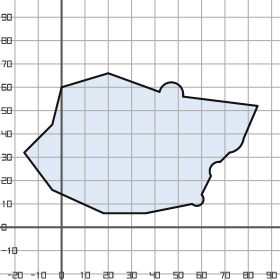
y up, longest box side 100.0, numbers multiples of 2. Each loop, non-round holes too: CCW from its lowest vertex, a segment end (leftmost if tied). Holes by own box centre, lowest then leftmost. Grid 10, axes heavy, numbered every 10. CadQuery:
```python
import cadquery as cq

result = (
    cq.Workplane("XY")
    .moveTo(18.0, 6.0)
    .lineTo(36.0, 6.0)
    .lineTo(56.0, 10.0)
    .threePointArc((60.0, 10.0), (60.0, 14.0))
    .lineTo(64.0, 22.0)
    .threePointArc((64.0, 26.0), (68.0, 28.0))
    .lineTo(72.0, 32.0)
    .threePointArc((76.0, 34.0), (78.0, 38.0))
    .lineTo(84.0, 52.0)
    .lineTo(52.0, 56.0)
    .threePointArc((48.0, 62.0), (42.0, 58.0))
    .lineTo(20.0, 66.0)
    .lineTo(0.0, 60.0)
    .lineTo(-4.0, 44.0)
    .lineTo(-16.0, 32.0)
    .lineTo(-4.0, 16.0)
    .close()
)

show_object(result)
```